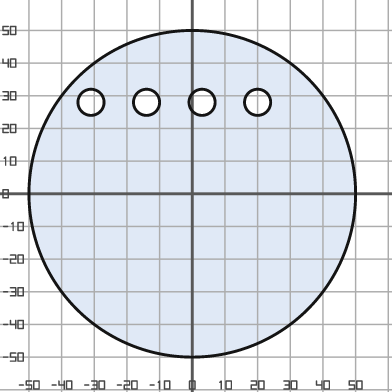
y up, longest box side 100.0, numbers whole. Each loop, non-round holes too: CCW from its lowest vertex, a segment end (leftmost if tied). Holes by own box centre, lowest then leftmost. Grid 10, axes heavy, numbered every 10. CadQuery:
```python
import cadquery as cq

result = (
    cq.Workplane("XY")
    .moveTo(0.0, 0.0)
    .circle(50.0)
    .moveTo(-31.0, 28.0)
    .circle(4.0)
    .moveTo(-14.0, 28.0)
    .circle(4.0)
    .moveTo(3.0, 28.0)
    .circle(4.0)
    .moveTo(20.0, 28.0)
    .circle(4.0)
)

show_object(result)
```